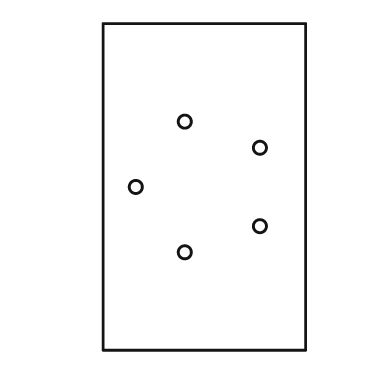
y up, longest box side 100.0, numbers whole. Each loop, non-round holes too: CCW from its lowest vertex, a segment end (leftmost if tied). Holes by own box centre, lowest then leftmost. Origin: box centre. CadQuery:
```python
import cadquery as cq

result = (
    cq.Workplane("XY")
    .moveTo(-31.0, -50.0)
    .lineTo(31.0, -50.0)
    .lineTo(31.0, 50.0)
    .lineTo(-31.0, 50.0)
    .close()
    .moveTo(-6.0, -20.0)
    .circle(2.0)
    .moveTo(17.0, -12.0)
    .circle(2.0)
    .moveTo(-21.0, 0.0)
    .circle(2.0)
    .moveTo(17.0, 12.0)
    .circle(2.0)
    .moveTo(-6.0, 20.0)
    .circle(2.0)
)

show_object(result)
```